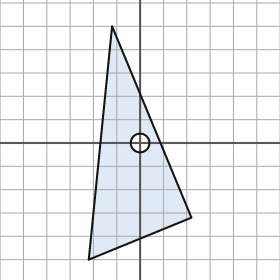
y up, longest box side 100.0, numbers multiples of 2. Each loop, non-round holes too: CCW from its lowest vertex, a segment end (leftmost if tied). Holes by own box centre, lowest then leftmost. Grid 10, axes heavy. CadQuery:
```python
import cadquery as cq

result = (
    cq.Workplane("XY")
    .moveTo(-22.0, -50.0)
    .lineTo(22.0, -32.0)
    .lineTo(-12.0, 50.0)
    .close()
    .moveTo(0.0, 0.0)
    .circle(4.0)
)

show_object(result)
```